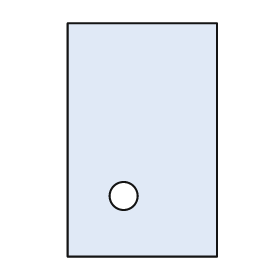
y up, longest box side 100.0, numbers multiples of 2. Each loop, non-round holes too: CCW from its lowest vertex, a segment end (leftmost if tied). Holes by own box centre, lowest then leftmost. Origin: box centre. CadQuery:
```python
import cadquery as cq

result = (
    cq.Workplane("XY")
    .moveTo(-32.0, -50.0)
    .lineTo(32.0, -50.0)
    .lineTo(32.0, 50.0)
    .lineTo(-32.0, 50.0)
    .close()
    .moveTo(-8.0, -24.0)
    .circle(6.0)
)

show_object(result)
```